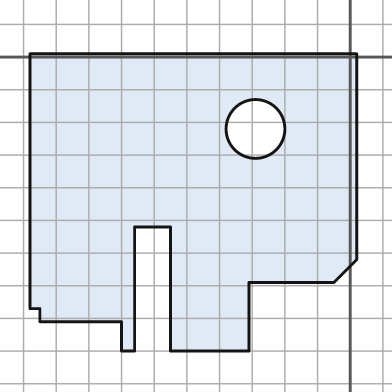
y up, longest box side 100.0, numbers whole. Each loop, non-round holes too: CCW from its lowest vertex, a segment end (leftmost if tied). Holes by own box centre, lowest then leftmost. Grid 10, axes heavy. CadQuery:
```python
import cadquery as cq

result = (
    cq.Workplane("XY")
    .moveTo(-70.0, -90.0)
    .lineTo(-66.0, -90.0)
    .lineTo(-66.0, -52.0)
    .lineTo(-55.0, -52.0)
    .lineTo(-55.0, -90.0)
    .lineTo(-31.0, -90.0)
    .lineTo(-31.0, -69.0)
    .lineTo(-5.0, -69.0)
    .lineTo(2.0, -62.0)
    .lineTo(2.0, 1.0)
    .lineTo(-98.0, 1.0)
    .lineTo(-98.0, -77.0)
    .lineTo(-95.0, -77.0)
    .lineTo(-95.0, -81.0)
    .lineTo(-70.0, -81.0)
    .close()
    .moveTo(-29.0, -22.0)
    .circle(9.0)
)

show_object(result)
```